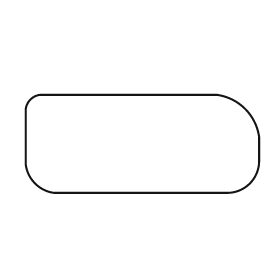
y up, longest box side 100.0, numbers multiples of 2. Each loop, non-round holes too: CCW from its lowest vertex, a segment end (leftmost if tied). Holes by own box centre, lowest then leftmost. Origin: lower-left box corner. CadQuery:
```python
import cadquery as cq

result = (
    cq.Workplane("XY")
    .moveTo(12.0, 0.0)
    .lineTo(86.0, 0.0)
    .threePointArc((96.0, 4.0), (100.0, 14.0))
    .lineTo(100.0, 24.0)
    .threePointArc((94.0, 36.0), (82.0, 42.0))
    .lineTo(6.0, 42.0)
    .threePointArc((2.0, 40.0), (0.0, 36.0))
    .lineTo(0.0, 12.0)
    .threePointArc((4.0, 4.0), (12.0, 0.0))
    .close()
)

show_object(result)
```